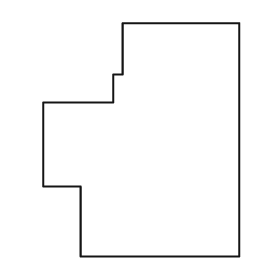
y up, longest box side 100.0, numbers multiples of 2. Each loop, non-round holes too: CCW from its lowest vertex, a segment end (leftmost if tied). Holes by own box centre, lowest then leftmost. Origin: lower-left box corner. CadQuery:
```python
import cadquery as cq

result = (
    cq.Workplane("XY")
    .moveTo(16.0, 0.0)
    .lineTo(84.0, 0.0)
    .lineTo(84.0, 100.0)
    .lineTo(34.0, 100.0)
    .lineTo(34.0, 78.0)
    .lineTo(30.0, 78.0)
    .lineTo(30.0, 66.0)
    .lineTo(0.0, 66.0)
    .lineTo(0.0, 30.0)
    .lineTo(16.0, 30.0)
    .close()
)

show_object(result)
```